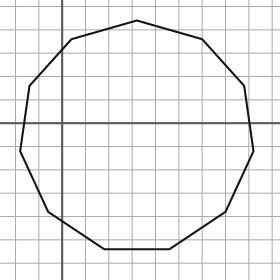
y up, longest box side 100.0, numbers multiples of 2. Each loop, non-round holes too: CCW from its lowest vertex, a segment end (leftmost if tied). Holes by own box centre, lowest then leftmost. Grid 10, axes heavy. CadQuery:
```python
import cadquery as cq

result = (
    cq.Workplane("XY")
    .moveTo(18.0, -54.0)
    .lineTo(46.0, -54.0)
    .lineTo(70.0, -38.0)
    .lineTo(82.0, -12.0)
    .lineTo(78.0, 16.0)
    .lineTo(60.0, 36.0)
    .lineTo(32.0, 44.0)
    .lineTo(4.0, 36.0)
    .lineTo(-14.0, 16.0)
    .lineTo(-18.0, -12.0)
    .lineTo(-6.0, -38.0)
    .close()
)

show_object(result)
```